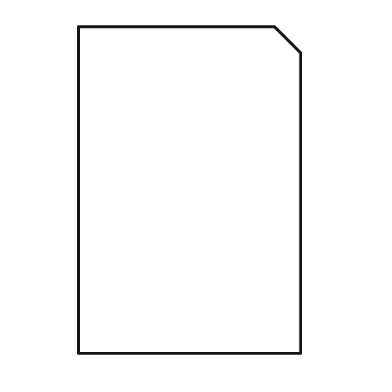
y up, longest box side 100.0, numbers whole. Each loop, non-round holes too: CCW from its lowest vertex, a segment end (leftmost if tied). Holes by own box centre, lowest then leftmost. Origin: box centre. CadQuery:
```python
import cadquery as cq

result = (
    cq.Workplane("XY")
    .moveTo(-34.0, -50.0)
    .lineTo(34.0, -50.0)
    .lineTo(34.0, 42.0)
    .lineTo(26.0, 50.0)
    .lineTo(-34.0, 50.0)
    .close()
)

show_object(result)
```